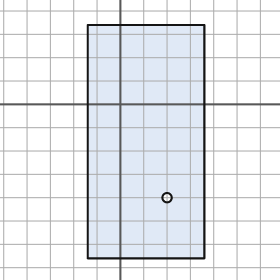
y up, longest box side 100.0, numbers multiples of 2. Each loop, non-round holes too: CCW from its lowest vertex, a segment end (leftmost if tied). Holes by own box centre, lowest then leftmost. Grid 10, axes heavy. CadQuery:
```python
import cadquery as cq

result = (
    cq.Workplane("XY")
    .moveTo(-14.0, -66.0)
    .lineTo(36.0, -66.0)
    .lineTo(36.0, 34.0)
    .lineTo(-14.0, 34.0)
    .close()
    .moveTo(20.0, -40.0)
    .circle(2.0)
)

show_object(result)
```